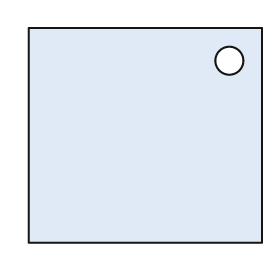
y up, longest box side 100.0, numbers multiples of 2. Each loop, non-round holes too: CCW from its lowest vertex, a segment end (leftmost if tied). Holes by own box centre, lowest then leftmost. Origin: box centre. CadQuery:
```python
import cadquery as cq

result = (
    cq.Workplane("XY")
    .moveTo(-50.0, -46.0)
    .lineTo(50.0, -46.0)
    .lineTo(50.0, 46.0)
    .lineTo(-50.0, 46.0)
    .close()
    .moveTo(36.0, 32.0)
    .circle(6.0)
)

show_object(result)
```